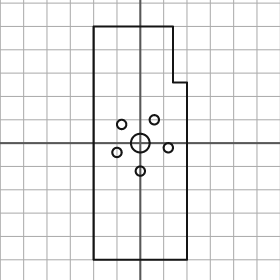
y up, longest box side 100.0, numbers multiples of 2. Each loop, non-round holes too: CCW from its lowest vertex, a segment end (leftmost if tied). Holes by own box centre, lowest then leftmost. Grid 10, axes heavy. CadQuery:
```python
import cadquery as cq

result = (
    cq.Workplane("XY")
    .moveTo(-20.0, -50.0)
    .lineTo(20.0, -50.0)
    .lineTo(20.0, 26.0)
    .lineTo(14.0, 26.0)
    .lineTo(14.0, 50.0)
    .lineTo(-20.0, 50.0)
    .close()
    .moveTo(0.0, -12.0)
    .circle(2.0)
    .moveTo(-10.0, -4.0)
    .circle(2.0)
    .moveTo(12.0, -2.0)
    .circle(2.0)
    .moveTo(0.0, 0.0)
    .circle(4.0)
    .moveTo(-8.0, 8.0)
    .circle(2.0)
    .moveTo(6.0, 10.0)
    .circle(2.0)
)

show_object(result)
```